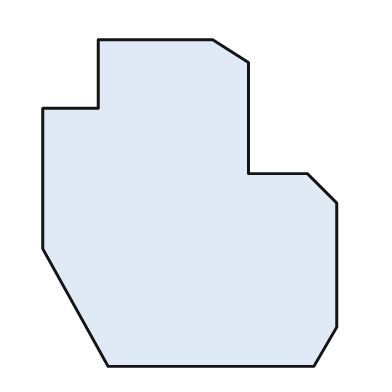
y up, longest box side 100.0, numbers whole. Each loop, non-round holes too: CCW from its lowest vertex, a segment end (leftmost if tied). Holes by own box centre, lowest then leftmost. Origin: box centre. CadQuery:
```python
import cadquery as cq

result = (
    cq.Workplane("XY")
    .moveTo(-25.0, -50.0)
    .lineTo(38.0, -50.0)
    .lineTo(45.0, -38.0)
    .lineTo(45.0, 0.0)
    .lineTo(36.0, 9.0)
    .lineTo(18.0, 9.0)
    .lineTo(18.0, 43.0)
    .lineTo(7.0, 50.0)
    .lineTo(-28.0, 50.0)
    .lineTo(-28.0, 29.0)
    .lineTo(-45.0, 29.0)
    .lineTo(-45.0, -14.0)
    .close()
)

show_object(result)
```